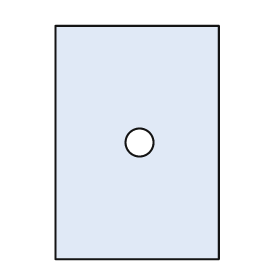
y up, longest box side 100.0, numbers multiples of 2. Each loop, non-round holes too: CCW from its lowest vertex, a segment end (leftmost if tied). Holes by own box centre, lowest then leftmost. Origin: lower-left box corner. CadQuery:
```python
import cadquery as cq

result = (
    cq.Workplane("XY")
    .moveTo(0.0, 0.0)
    .lineTo(70.0, 0.0)
    .lineTo(70.0, 100.0)
    .lineTo(0.0, 100.0)
    .close()
    .moveTo(36.0, 50.0)
    .circle(6.0)
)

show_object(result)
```